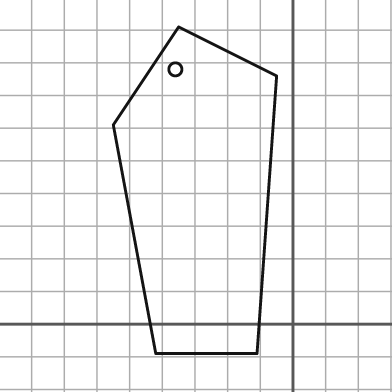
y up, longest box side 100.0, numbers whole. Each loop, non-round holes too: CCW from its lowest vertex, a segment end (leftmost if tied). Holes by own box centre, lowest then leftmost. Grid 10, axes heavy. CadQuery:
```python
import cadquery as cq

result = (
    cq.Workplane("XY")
    .moveTo(-42.0, -9.0)
    .lineTo(-11.0, -9.0)
    .lineTo(-5.0, 76.0)
    .lineTo(-35.0, 91.0)
    .lineTo(-55.0, 61.0)
    .close()
    .moveTo(-36.0, 78.0)
    .circle(2.0)
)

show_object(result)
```